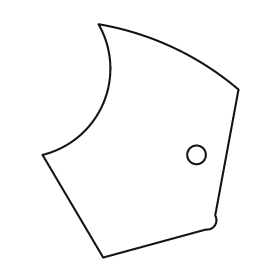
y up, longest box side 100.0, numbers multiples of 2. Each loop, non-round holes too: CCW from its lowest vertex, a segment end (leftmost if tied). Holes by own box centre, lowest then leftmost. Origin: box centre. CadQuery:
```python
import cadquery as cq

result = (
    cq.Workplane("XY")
    .moveTo(-16.0, -50.0)
    .lineTo(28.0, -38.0)
    .threePointArc((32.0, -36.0), (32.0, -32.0))
    .lineTo(42.0, 22.0)
    .threePointArc((14.0, 40.0), (-18.0, 50.0))
    .threePointArc((-16.0, 16.0), (-42.0, -6.0))
    .close()
    .moveTo(24.0, -6.0)
    .circle(4.0)
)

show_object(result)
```